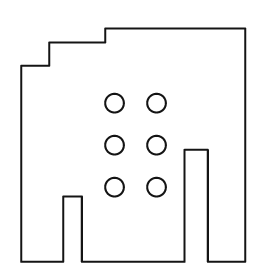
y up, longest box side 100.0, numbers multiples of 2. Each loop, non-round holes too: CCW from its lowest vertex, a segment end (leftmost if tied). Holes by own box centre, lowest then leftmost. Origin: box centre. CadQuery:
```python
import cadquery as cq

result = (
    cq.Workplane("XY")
    .moveTo(-48.0, -50.0)
    .lineTo(-30.0, -50.0)
    .lineTo(-30.0, -22.0)
    .lineTo(-22.0, -22.0)
    .lineTo(-22.0, -50.0)
    .lineTo(22.0, -50.0)
    .lineTo(22.0, -2.0)
    .lineTo(32.0, -2.0)
    .lineTo(32.0, -50.0)
    .lineTo(48.0, -50.0)
    .lineTo(48.0, 50.0)
    .lineTo(-12.0, 50.0)
    .lineTo(-12.0, 44.0)
    .lineTo(-36.0, 44.0)
    .lineTo(-36.0, 34.0)
    .lineTo(-48.0, 34.0)
    .close()
    .moveTo(-8.0, -18.0)
    .circle(4.0)
    .moveTo(10.0, -18.0)
    .circle(4.0)
    .moveTo(-8.0, 0.0)
    .circle(4.0)
    .moveTo(10.0, 0.0)
    .circle(4.0)
    .moveTo(-8.0, 18.0)
    .circle(4.0)
    .moveTo(10.0, 18.0)
    .circle(4.0)
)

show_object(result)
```